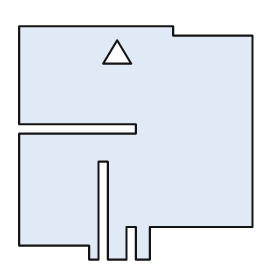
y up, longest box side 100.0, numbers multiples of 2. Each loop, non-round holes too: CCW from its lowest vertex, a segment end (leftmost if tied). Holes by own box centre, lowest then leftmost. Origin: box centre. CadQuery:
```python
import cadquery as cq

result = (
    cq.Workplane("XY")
    .moveTo(-20.0, -50.0)
    .lineTo(-16.0, -50.0)
    .lineTo(-16.0, -8.0)
    .lineTo(-12.0, -8.0)
    .lineTo(-12.0, -50.0)
    .lineTo(-4.0, -50.0)
    .lineTo(-4.0, -36.0)
    .lineTo(0.0, -36.0)
    .lineTo(0.0, -50.0)
    .lineTo(6.0, -50.0)
    .lineTo(6.0, -36.0)
    .lineTo(50.0, -36.0)
    .lineTo(50.0, 46.0)
    .lineTo(16.0, 46.0)
    .lineTo(16.0, 50.0)
    .lineTo(-50.0, 50.0)
    .lineTo(-50.0, 8.0)
    .lineTo(0.0, 8.0)
    .lineTo(0.0, 4.0)
    .lineTo(-50.0, 4.0)
    .lineTo(-50.0, -44.0)
    .lineTo(-20.0, -44.0)
    .close()
    .moveTo(-14.0, 34.0)
    .lineTo(-2.0, 34.0)
    .lineTo(-8.0, 44.0)
    .close()
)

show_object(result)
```